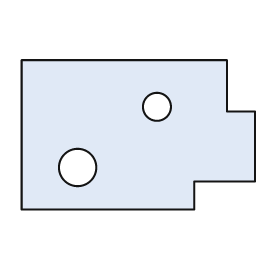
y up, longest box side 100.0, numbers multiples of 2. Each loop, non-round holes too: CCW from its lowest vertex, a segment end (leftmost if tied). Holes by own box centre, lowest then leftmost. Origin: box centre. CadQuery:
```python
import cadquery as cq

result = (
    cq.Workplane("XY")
    .moveTo(-50.0, -32.0)
    .lineTo(24.0, -32.0)
    .lineTo(24.0, -20.0)
    .lineTo(50.0, -20.0)
    .lineTo(50.0, 10.0)
    .lineTo(38.0, 10.0)
    .lineTo(38.0, 32.0)
    .lineTo(-50.0, 32.0)
    .close()
    .moveTo(-26.0, -14.0)
    .circle(8.0)
    .moveTo(8.0, 12.0)
    .circle(6.0)
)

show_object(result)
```